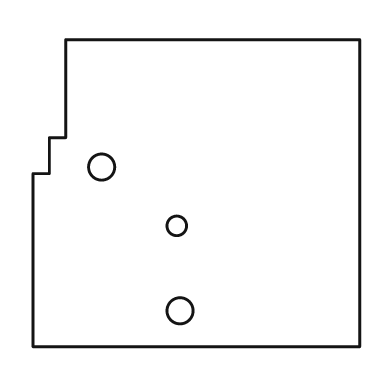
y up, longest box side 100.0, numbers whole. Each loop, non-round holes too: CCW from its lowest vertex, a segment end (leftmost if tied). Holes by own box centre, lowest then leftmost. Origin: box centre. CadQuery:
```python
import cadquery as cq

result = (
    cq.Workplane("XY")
    .moveTo(-50.0, -47.0)
    .lineTo(50.0, -47.0)
    .lineTo(50.0, 47.0)
    .lineTo(-40.0, 47.0)
    .lineTo(-40.0, 17.0)
    .lineTo(-45.0, 17.0)
    .lineTo(-45.0, 6.0)
    .lineTo(-50.0, 6.0)
    .close()
    .moveTo(-5.0, -36.0)
    .circle(4.0)
    .moveTo(-6.0, -10.0)
    .circle(3.0)
    .moveTo(-29.0, 8.0)
    .circle(4.0)
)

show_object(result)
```